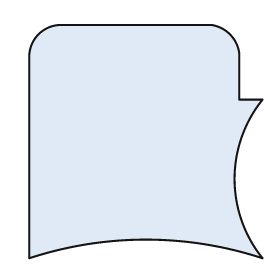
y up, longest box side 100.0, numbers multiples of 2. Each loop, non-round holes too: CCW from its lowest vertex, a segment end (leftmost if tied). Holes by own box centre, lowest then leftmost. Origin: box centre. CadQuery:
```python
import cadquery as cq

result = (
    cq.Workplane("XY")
    .moveTo(-50.0, -50.0)
    .threePointArc((0.0, -42.0), (50.0, -50.0))
    .threePointArc((38.0, -16.0), (50.0, 18.0))
    .lineTo(40.0, 18.0)
    .lineTo(40.0, 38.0)
    .threePointArc((36.0, 46.0), (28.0, 50.0))
    .lineTo(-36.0, 50.0)
    .threePointArc((-46.0, 46.0), (-50.0, 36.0))
    .close()
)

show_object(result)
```